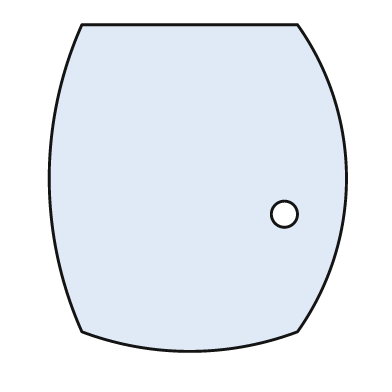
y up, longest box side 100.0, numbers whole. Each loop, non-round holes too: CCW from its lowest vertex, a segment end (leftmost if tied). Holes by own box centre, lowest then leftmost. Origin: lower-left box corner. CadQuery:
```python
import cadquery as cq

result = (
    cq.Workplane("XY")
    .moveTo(10.0, 6.0)
    .threePointArc((43.0, 0.0), (76.0, 6.0))
    .threePointArc((91.0, 53.0), (76.0, 100.0))
    .lineTo(10.0, 100.0)
    .threePointArc((0.0, 53.0), (10.0, 6.0))
    .close()
    .moveTo(72.0, 42.0)
    .circle(4.0)
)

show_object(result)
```